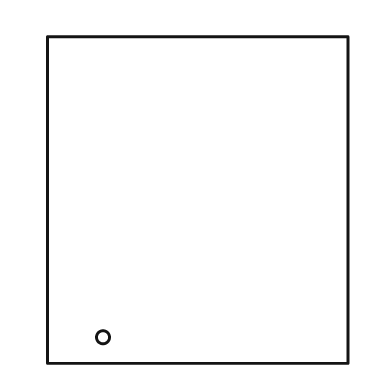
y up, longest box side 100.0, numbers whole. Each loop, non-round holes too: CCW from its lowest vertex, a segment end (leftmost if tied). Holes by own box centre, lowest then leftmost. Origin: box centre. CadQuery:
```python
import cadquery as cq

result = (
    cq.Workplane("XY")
    .moveTo(-46.0, -50.0)
    .lineTo(46.0, -50.0)
    .lineTo(46.0, 50.0)
    .lineTo(-46.0, 50.0)
    .close()
    .moveTo(-29.0, -42.0)
    .circle(2.0)
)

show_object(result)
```